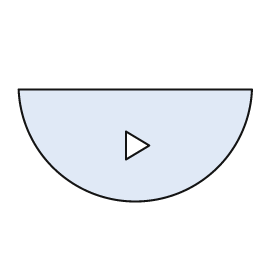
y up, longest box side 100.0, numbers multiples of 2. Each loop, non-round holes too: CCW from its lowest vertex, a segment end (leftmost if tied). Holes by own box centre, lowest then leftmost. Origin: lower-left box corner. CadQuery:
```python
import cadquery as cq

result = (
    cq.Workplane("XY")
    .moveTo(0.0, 48.0)
    .threePointArc((50.0, 0.0), (100.0, 48.0))
    .close()
    .moveTo(46.0, 18.0)
    .lineTo(56.0, 24.0)
    .lineTo(46.0, 30.0)
    .close()
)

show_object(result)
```